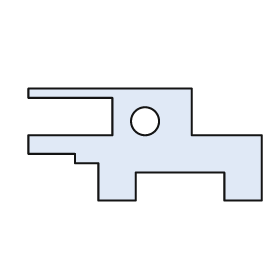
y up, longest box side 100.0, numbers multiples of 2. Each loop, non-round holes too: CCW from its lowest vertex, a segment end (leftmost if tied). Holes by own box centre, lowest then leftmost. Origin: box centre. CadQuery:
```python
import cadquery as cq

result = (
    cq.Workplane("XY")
    .moveTo(-20.0, -24.0)
    .lineTo(-4.0, -24.0)
    .lineTo(-4.0, -12.0)
    .lineTo(34.0, -12.0)
    .lineTo(34.0, -24.0)
    .lineTo(50.0, -24.0)
    .lineTo(50.0, 4.0)
    .lineTo(20.0, 4.0)
    .lineTo(20.0, 24.0)
    .lineTo(-50.0, 24.0)
    .lineTo(-50.0, 20.0)
    .lineTo(-14.0, 20.0)
    .lineTo(-14.0, 4.0)
    .lineTo(-50.0, 4.0)
    .lineTo(-50.0, -4.0)
    .lineTo(-30.0, -4.0)
    .lineTo(-30.0, -8.0)
    .lineTo(-20.0, -8.0)
    .close()
    .moveTo(0.0, 10.0)
    .circle(6.0)
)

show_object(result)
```